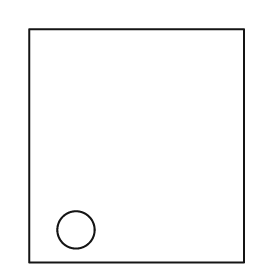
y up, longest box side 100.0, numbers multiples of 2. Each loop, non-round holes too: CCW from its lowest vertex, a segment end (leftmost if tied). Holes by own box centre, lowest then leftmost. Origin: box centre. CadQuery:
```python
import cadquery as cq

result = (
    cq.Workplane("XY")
    .moveTo(-46.0, -50.0)
    .lineTo(46.0, -50.0)
    .lineTo(46.0, 50.0)
    .lineTo(-46.0, 50.0)
    .close()
    .moveTo(-26.0, -36.0)
    .circle(8.0)
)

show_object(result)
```